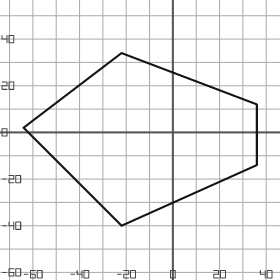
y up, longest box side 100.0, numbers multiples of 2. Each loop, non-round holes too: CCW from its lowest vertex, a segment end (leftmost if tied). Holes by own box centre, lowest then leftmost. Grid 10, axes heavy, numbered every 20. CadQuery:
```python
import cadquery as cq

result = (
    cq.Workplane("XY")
    .moveTo(-22.0, -40.0)
    .lineTo(36.0, -14.0)
    .lineTo(36.0, 12.0)
    .lineTo(-22.0, 34.0)
    .lineTo(-64.0, 2.0)
    .close()
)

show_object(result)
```